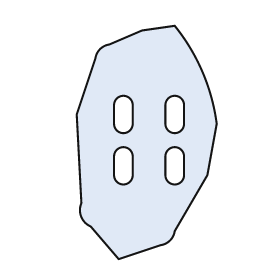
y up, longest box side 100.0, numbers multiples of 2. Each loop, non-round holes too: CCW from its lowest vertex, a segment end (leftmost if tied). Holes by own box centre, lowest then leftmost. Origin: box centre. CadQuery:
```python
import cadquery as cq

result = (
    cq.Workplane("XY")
    .moveTo(-12.0, -50.0)
    .lineTo(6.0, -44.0)
    .threePointArc((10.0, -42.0), (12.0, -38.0))
    .lineTo(26.0, -14.0)
    .lineTo(30.0, 8.0)
    .threePointArc((24.0, 30.0), (12.0, 50.0))
    .lineTo(-2.0, 48.0)
    .lineTo(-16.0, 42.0)
    .threePointArc((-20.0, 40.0), (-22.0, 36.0))
    .lineTo(-30.0, 12.0)
    .lineTo(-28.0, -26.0)
    .threePointArc((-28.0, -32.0), (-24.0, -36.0))
    .close()
    .moveTo(-14.0, -14.0)
    .threePointArc((-10.0, -18.0), (-6.0, -14.0))
    .lineTo(-6.0, -6.0)
    .threePointArc((-10.0, -2.0), (-14.0, -6.0))
    .close()
    .moveTo(8.0, -14.0)
    .threePointArc((12.0, -18.0), (16.0, -14.0))
    .lineTo(16.0, -6.0)
    .threePointArc((12.0, -2.0), (8.0, -6.0))
    .close()
    .moveTo(-14.0, 8.0)
    .threePointArc((-10.0, 4.0), (-6.0, 8.0))
    .lineTo(-6.0, 16.0)
    .threePointArc((-10.0, 20.0), (-14.0, 16.0))
    .close()
    .moveTo(8.0, 8.0)
    .threePointArc((12.0, 4.0), (16.0, 8.0))
    .lineTo(16.0, 16.0)
    .threePointArc((12.0, 20.0), (8.0, 16.0))
    .close()
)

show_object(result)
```